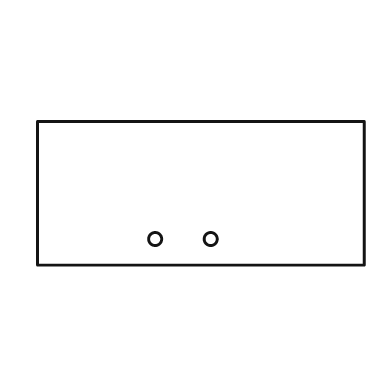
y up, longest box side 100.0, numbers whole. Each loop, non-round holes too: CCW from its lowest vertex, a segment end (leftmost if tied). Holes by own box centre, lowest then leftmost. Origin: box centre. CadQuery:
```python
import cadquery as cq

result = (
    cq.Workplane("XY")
    .moveTo(-50.0, -22.0)
    .lineTo(50.0, -22.0)
    .lineTo(50.0, 22.0)
    .lineTo(-50.0, 22.0)
    .close()
    .moveTo(-14.0, -14.0)
    .circle(2.0)
    .moveTo(3.0, -14.0)
    .circle(2.0)
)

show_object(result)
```